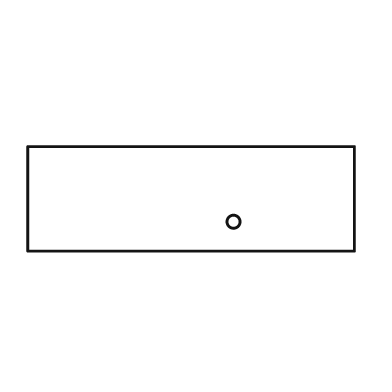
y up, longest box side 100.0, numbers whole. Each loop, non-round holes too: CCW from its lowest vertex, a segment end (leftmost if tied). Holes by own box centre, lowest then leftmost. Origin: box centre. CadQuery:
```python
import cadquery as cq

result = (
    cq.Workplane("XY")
    .moveTo(-50.0, -16.0)
    .lineTo(50.0, -16.0)
    .lineTo(50.0, 16.0)
    .lineTo(-50.0, 16.0)
    .close()
    .moveTo(13.0, -7.0)
    .circle(2.0)
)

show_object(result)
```